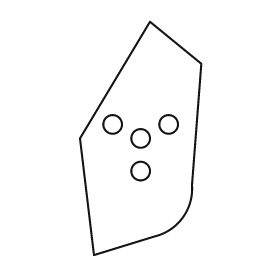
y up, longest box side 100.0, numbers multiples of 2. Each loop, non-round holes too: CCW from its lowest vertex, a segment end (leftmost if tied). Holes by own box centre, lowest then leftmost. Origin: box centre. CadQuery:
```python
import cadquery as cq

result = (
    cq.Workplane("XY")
    .moveTo(-20.0, -50.0)
    .lineTo(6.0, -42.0)
    .threePointArc((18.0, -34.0), (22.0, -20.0))
    .lineTo(26.0, 32.0)
    .lineTo(4.0, 50.0)
    .lineTo(-26.0, 0.0)
    .close()
    .moveTo(0.0, -14.0)
    .circle(4.0)
    .moveTo(0.0, 0.0)
    .circle(4.0)
    .moveTo(-12.0, 6.0)
    .circle(4.0)
    .moveTo(12.0, 6.0)
    .circle(4.0)
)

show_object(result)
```